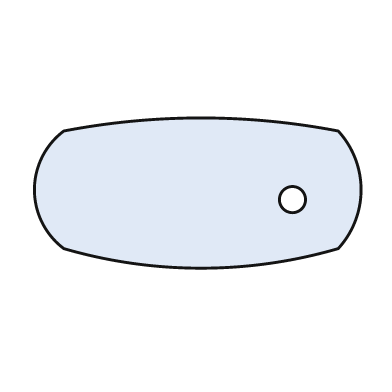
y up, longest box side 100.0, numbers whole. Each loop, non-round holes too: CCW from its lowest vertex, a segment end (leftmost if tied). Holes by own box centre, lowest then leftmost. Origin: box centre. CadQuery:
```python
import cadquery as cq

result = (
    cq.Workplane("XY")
    .moveTo(-41.0, -17.0)
    .threePointArc((1.0, -23.0), (43.0, -17.0))
    .threePointArc((50.0, 1.0), (43.0, 19.0))
    .threePointArc((1.0, 23.0), (-41.0, 19.0))
    .threePointArc((-50.0, 1.0), (-41.0, -17.0))
    .close()
    .moveTo(29.0, -2.0)
    .circle(4.0)
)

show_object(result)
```